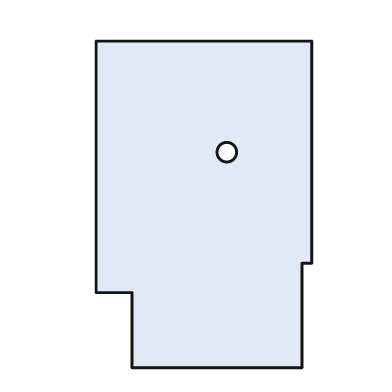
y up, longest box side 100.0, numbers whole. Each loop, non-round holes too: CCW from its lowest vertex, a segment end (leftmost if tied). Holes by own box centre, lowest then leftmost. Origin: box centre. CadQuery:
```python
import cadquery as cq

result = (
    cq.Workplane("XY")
    .moveTo(-22.0, -50.0)
    .lineTo(30.0, -50.0)
    .lineTo(30.0, -18.0)
    .lineTo(33.0, -18.0)
    .lineTo(33.0, 50.0)
    .lineTo(-33.0, 50.0)
    .lineTo(-33.0, -27.0)
    .lineTo(-22.0, -27.0)
    .close()
    .moveTo(7.0, 16.0)
    .circle(3.0)
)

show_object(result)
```